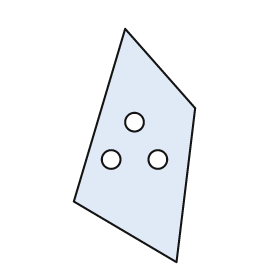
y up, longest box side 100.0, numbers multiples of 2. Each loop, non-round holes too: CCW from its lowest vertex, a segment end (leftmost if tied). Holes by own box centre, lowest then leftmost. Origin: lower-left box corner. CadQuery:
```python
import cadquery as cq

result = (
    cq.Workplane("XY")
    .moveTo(44.0, 0.0)
    .lineTo(52.0, 66.0)
    .lineTo(22.0, 100.0)
    .lineTo(0.0, 26.0)
    .close()
    .moveTo(16.0, 44.0)
    .circle(4.0)
    .moveTo(36.0, 44.0)
    .circle(4.0)
    .moveTo(26.0, 60.0)
    .circle(4.0)
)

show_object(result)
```